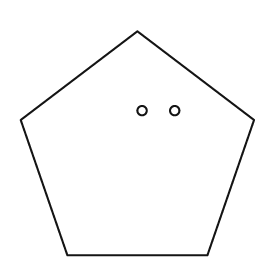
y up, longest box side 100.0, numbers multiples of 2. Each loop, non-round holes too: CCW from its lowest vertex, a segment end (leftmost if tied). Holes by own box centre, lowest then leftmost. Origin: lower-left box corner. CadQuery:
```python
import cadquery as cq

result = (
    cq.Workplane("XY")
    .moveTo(20.0, 0.0)
    .lineTo(80.0, 0.0)
    .lineTo(100.0, 58.0)
    .lineTo(50.0, 96.0)
    .lineTo(0.0, 58.0)
    .close()
    .moveTo(52.0, 62.0)
    .circle(2.0)
    .moveTo(66.0, 62.0)
    .circle(2.0)
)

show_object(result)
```